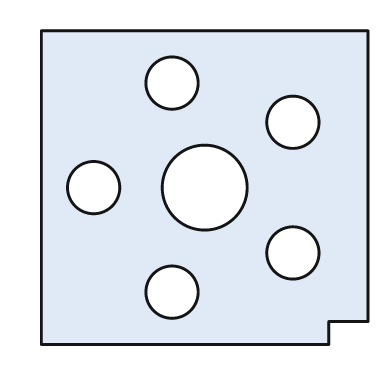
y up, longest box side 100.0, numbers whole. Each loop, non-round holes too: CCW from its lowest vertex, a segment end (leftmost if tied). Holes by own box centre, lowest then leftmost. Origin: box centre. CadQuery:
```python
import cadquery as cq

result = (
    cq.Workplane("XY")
    .moveTo(-50.0, -48.0)
    .lineTo(38.0, -48.0)
    .lineTo(38.0, -41.0)
    .lineTo(50.0, -41.0)
    .lineTo(50.0, 48.0)
    .lineTo(-50.0, 48.0)
    .close()
    .moveTo(-10.0, -32.0)
    .circle(8.0)
    .moveTo(27.0, -20.0)
    .circle(8.0)
    .moveTo(-34.0, 0.0)
    .circle(8.0)
    .moveTo(0.0, 0.0)
    .circle(13.0)
    .moveTo(27.0, 20.0)
    .circle(8.0)
    .moveTo(-10.0, 32.0)
    .circle(8.0)
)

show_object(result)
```